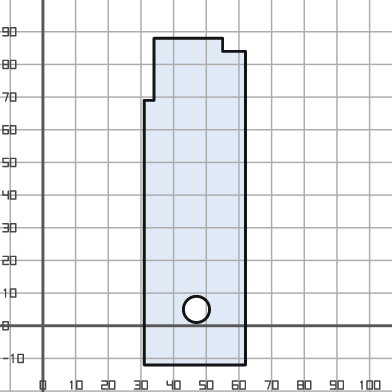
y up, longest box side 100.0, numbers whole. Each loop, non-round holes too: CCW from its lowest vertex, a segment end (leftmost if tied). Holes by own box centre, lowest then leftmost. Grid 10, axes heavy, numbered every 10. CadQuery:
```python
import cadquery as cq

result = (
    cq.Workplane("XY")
    .moveTo(31.0, -12.0)
    .lineTo(62.0, -12.0)
    .lineTo(62.0, 84.0)
    .lineTo(55.0, 84.0)
    .lineTo(55.0, 88.0)
    .lineTo(34.0, 88.0)
    .lineTo(34.0, 69.0)
    .lineTo(31.0, 69.0)
    .close()
    .moveTo(47.0, 5.0)
    .circle(4.0)
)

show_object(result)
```